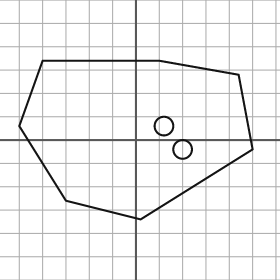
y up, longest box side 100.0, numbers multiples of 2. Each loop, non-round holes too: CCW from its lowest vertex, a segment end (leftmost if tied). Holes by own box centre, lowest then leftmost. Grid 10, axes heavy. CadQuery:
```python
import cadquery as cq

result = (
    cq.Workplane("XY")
    .moveTo(2.0, -34.0)
    .lineTo(50.0, -4.0)
    .lineTo(44.0, 28.0)
    .lineTo(10.0, 34.0)
    .lineTo(-40.0, 34.0)
    .lineTo(-50.0, 6.0)
    .lineTo(-30.0, -26.0)
    .close()
    .moveTo(20.0, -4.0)
    .circle(4.0)
    .moveTo(12.0, 6.0)
    .circle(4.0)
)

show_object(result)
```